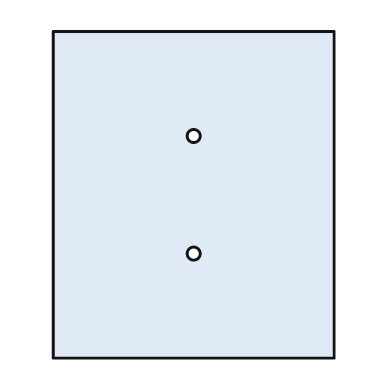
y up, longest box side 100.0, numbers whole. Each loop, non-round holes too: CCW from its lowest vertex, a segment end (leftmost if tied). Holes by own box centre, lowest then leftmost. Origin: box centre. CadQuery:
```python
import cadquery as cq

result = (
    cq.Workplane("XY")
    .moveTo(-43.0, -50.0)
    .lineTo(43.0, -50.0)
    .lineTo(43.0, 50.0)
    .lineTo(-43.0, 50.0)
    .close()
    .moveTo(0.0, -18.0)
    .circle(2.0)
    .moveTo(0.0, 18.0)
    .circle(2.0)
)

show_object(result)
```